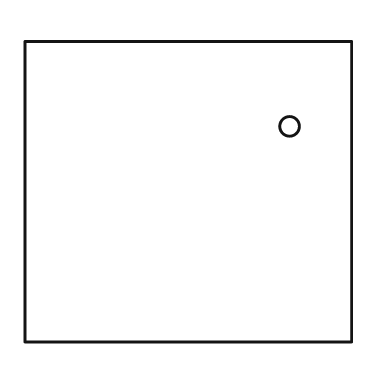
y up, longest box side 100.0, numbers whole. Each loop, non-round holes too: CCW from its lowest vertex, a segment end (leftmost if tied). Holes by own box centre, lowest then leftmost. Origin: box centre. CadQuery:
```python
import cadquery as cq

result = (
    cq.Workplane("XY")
    .moveTo(-50.0, -46.0)
    .lineTo(50.0, -46.0)
    .lineTo(50.0, 46.0)
    .lineTo(-50.0, 46.0)
    .close()
    .moveTo(31.0, 20.0)
    .circle(3.0)
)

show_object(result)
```